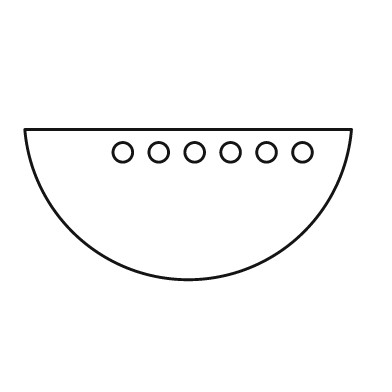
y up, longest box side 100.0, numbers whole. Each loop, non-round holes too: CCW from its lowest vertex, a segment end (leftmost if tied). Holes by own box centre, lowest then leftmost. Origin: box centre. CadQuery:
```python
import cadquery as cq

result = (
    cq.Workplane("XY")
    .moveTo(-50.0, 23.0)
    .threePointArc((0.0, -23.0), (50.0, 23.0))
    .close()
    .moveTo(-20.0, 16.0)
    .circle(3.0)
    .moveTo(-9.0, 16.0)
    .circle(3.0)
    .moveTo(2.0, 16.0)
    .circle(3.0)
    .moveTo(13.0, 16.0)
    .circle(3.0)
    .moveTo(24.0, 16.0)
    .circle(3.0)
    .moveTo(35.0, 16.0)
    .circle(3.0)
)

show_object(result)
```